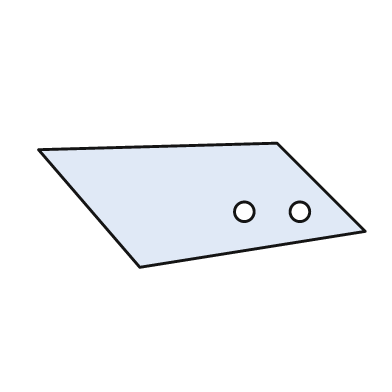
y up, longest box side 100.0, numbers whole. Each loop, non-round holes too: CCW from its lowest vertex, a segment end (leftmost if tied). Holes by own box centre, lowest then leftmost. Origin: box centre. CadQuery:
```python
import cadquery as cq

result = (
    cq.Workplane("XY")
    .moveTo(-19.0, -19.0)
    .lineTo(50.0, -8.0)
    .lineTo(23.0, 19.0)
    .lineTo(-50.0, 17.0)
    .close()
    .moveTo(13.0, -2.0)
    .circle(3.0)
    .moveTo(30.0, -2.0)
    .circle(3.0)
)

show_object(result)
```